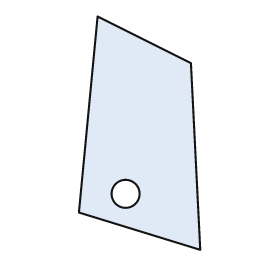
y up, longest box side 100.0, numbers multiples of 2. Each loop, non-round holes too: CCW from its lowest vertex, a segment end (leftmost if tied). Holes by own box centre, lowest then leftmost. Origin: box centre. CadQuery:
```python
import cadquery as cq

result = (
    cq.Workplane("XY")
    .moveTo(26.0, -50.0)
    .lineTo(22.0, 30.0)
    .lineTo(-18.0, 50.0)
    .lineTo(-26.0, -34.0)
    .close()
    .moveTo(-6.0, -26.0)
    .circle(6.0)
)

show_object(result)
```